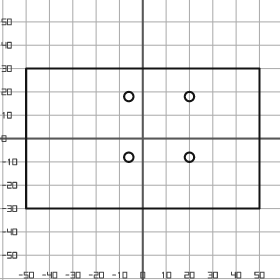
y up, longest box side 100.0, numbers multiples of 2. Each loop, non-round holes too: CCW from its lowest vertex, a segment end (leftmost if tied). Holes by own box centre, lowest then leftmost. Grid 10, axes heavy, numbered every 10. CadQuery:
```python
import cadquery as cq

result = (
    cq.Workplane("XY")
    .moveTo(-50.0, -30.0)
    .lineTo(50.0, -30.0)
    .lineTo(50.0, 30.0)
    .lineTo(-50.0, 30.0)
    .close()
    .moveTo(-6.0, -8.0)
    .circle(2.0)
    .moveTo(20.0, -8.0)
    .circle(2.0)
    .moveTo(-6.0, 18.0)
    .circle(2.0)
    .moveTo(20.0, 18.0)
    .circle(2.0)
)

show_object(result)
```